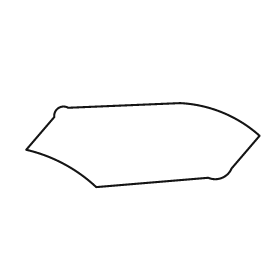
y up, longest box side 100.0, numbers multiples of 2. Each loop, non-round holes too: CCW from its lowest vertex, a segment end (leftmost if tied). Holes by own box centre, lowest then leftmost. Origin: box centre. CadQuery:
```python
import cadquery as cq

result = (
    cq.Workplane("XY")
    .moveTo(-20.0, -18.0)
    .lineTo(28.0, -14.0)
    .threePointArc((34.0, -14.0), (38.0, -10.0))
    .lineTo(50.0, 4.0)
    .threePointArc((34.0, 14.0), (16.0, 18.0))
    .lineTo(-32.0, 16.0)
    .threePointArc((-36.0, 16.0), (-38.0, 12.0))
    .lineTo(-50.0, -2.0)
    .threePointArc((-34.0, -8.0), (-20.0, -18.0))
    .close()
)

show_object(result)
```